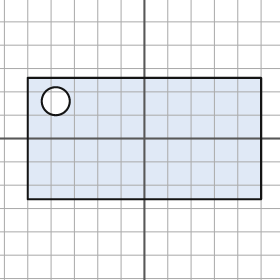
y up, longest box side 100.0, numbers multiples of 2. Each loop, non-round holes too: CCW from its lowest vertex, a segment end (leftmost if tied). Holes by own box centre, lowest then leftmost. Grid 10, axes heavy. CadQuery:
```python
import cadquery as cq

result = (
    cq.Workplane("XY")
    .moveTo(-50.0, -26.0)
    .lineTo(50.0, -26.0)
    .lineTo(50.0, 26.0)
    .lineTo(-50.0, 26.0)
    .close()
    .moveTo(-38.0, 16.0)
    .circle(6.0)
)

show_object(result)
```